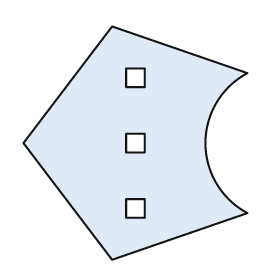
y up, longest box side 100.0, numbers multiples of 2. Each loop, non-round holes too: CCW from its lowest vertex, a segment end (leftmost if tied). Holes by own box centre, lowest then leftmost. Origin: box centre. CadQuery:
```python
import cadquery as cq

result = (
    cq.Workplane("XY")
    .moveTo(-10.0, -50.0)
    .lineTo(48.0, -30.0)
    .threePointArc((30.0, 0.0), (48.0, 30.0))
    .lineTo(-10.0, 50.0)
    .lineTo(-48.0, 0.0)
    .close()
    .moveTo(-4.0, -32.0)
    .lineTo(4.0, -32.0)
    .lineTo(4.0, -24.0)
    .lineTo(-4.0, -24.0)
    .close()
    .moveTo(-4.0, -4.0)
    .lineTo(4.0, -4.0)
    .lineTo(4.0, 4.0)
    .lineTo(-4.0, 4.0)
    .close()
    .moveTo(-4.0, 24.0)
    .lineTo(4.0, 24.0)
    .lineTo(4.0, 32.0)
    .lineTo(-4.0, 32.0)
    .close()
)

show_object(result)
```